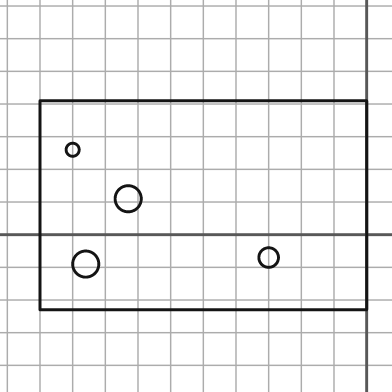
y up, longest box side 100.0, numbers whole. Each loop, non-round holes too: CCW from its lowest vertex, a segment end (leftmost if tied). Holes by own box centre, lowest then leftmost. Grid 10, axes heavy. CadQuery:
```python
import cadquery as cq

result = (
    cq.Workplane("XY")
    .moveTo(-100.0, -23.0)
    .lineTo(0.0, -23.0)
    .lineTo(0.0, 41.0)
    .lineTo(-100.0, 41.0)
    .close()
    .moveTo(-86.0, -9.0)
    .circle(4.0)
    .moveTo(-30.0, -7.0)
    .circle(3.0)
    .moveTo(-73.0, 11.0)
    .circle(4.0)
    .moveTo(-90.0, 26.0)
    .circle(2.0)
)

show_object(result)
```